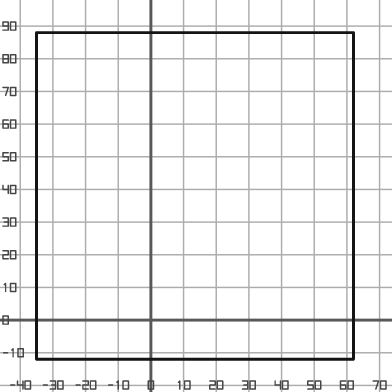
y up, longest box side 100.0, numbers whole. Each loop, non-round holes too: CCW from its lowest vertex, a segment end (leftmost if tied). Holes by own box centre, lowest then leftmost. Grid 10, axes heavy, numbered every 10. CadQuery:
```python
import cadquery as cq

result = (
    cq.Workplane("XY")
    .moveTo(-35.0, -12.0)
    .lineTo(62.0, -12.0)
    .lineTo(62.0, 88.0)
    .lineTo(-35.0, 88.0)
    .close()
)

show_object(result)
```